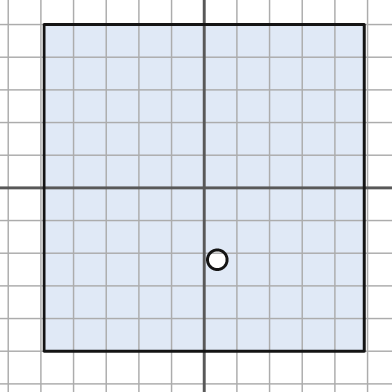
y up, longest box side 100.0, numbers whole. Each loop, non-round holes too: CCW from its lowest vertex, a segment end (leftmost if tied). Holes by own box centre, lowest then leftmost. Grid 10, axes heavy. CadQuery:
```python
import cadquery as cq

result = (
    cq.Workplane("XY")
    .moveTo(-49.0, -50.0)
    .lineTo(49.0, -50.0)
    .lineTo(49.0, 50.0)
    .lineTo(-49.0, 50.0)
    .close()
    .moveTo(4.0, -22.0)
    .circle(3.0)
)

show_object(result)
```